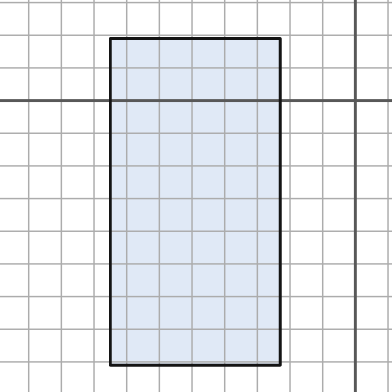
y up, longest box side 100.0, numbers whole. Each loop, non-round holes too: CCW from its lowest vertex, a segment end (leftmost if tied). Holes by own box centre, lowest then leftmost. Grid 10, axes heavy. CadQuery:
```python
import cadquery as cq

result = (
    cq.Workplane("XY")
    .moveTo(-75.0, -81.0)
    .lineTo(-23.0, -81.0)
    .lineTo(-23.0, 19.0)
    .lineTo(-75.0, 19.0)
    .close()
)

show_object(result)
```